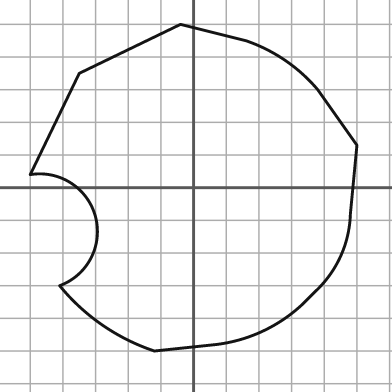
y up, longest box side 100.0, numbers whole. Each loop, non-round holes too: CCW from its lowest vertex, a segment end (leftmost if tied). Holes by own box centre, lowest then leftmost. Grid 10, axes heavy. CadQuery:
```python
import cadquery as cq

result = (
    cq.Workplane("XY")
    .moveTo(-12.0, -50.0)
    .lineTo(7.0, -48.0)
    .threePointArc((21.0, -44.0), (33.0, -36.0))
    .lineTo(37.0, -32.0)
    .threePointArc((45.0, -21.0), (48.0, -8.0))
    .lineTo(50.0, 13.0)
    .lineTo(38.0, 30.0)
    .threePointArc((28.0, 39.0), (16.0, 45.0))
    .lineTo(-4.0, 50.0)
    .lineTo(-35.0, 35.0)
    .lineTo(-50.0, 4.0)
    .threePointArc((-30.0, -9.0), (-41.0, -30.0))
    .threePointArc((-28.0, -42.0), (-12.0, -50.0))
    .close()
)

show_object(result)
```